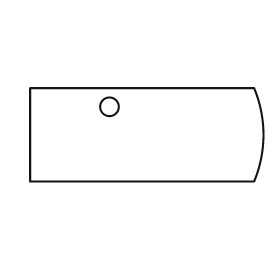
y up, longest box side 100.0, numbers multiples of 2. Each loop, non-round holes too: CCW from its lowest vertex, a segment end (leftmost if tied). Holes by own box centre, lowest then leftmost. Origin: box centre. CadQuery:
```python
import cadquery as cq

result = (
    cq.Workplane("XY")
    .moveTo(-50.0, -20.0)
    .lineTo(46.0, -20.0)
    .threePointArc((50.0, 0.0), (46.0, 20.0))
    .lineTo(-50.0, 20.0)
    .close()
    .moveTo(-16.0, 12.0)
    .circle(4.0)
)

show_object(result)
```